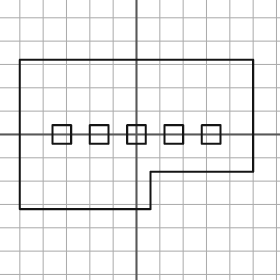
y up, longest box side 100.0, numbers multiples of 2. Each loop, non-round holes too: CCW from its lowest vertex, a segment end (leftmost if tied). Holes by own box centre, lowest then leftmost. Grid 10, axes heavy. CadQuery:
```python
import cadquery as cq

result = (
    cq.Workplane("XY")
    .moveTo(-50.0, -32.0)
    .lineTo(6.0, -32.0)
    .lineTo(6.0, -16.0)
    .lineTo(50.0, -16.0)
    .lineTo(50.0, 32.0)
    .lineTo(-50.0, 32.0)
    .close()
    .moveTo(-36.0, -4.0)
    .lineTo(-28.0, -4.0)
    .lineTo(-28.0, 4.0)
    .lineTo(-36.0, 4.0)
    .close()
    .moveTo(-20.0, -4.0)
    .lineTo(-12.0, -4.0)
    .lineTo(-12.0, 4.0)
    .lineTo(-20.0, 4.0)
    .close()
    .moveTo(-4.0, -4.0)
    .lineTo(4.0, -4.0)
    .lineTo(4.0, 4.0)
    .lineTo(-4.0, 4.0)
    .close()
    .moveTo(12.0, -4.0)
    .lineTo(20.0, -4.0)
    .lineTo(20.0, 4.0)
    .lineTo(12.0, 4.0)
    .close()
    .moveTo(28.0, -4.0)
    .lineTo(36.0, -4.0)
    .lineTo(36.0, 4.0)
    .lineTo(28.0, 4.0)
    .close()
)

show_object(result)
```